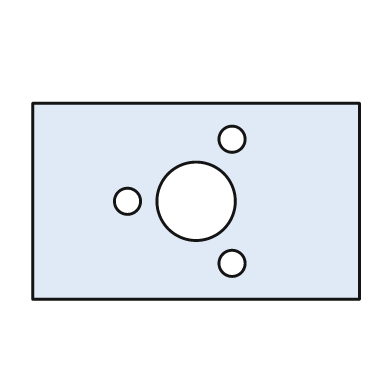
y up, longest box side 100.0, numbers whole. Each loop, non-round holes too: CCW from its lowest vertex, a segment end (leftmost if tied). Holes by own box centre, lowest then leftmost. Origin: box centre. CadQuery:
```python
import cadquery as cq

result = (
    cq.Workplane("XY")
    .moveTo(-50.0, -30.0)
    .lineTo(50.0, -30.0)
    .lineTo(50.0, 30.0)
    .lineTo(-50.0, 30.0)
    .close()
    .moveTo(11.0, -19.0)
    .circle(4.0)
    .moveTo(-21.0, 0.0)
    .circle(4.0)
    .moveTo(0.0, 0.0)
    .circle(12.0)
    .moveTo(11.0, 19.0)
    .circle(4.0)
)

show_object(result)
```